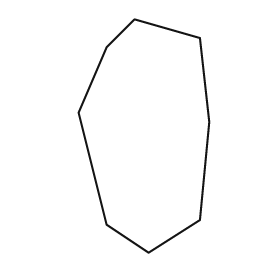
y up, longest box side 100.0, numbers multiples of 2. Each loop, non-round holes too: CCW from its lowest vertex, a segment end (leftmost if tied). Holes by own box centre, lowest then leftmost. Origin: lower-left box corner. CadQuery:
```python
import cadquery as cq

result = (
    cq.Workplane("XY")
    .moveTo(30.0, 0.0)
    .lineTo(52.0, 14.0)
    .lineTo(56.0, 56.0)
    .lineTo(52.0, 92.0)
    .lineTo(24.0, 100.0)
    .lineTo(12.0, 88.0)
    .lineTo(0.0, 60.0)
    .lineTo(12.0, 12.0)
    .close()
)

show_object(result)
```